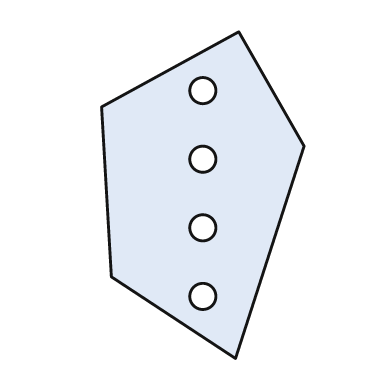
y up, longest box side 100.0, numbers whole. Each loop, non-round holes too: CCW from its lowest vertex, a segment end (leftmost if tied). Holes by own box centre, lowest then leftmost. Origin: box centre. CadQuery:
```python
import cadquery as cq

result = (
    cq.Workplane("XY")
    .moveTo(10.0, -50.0)
    .lineTo(31.0, 15.0)
    .lineTo(11.0, 50.0)
    .lineTo(-31.0, 27.0)
    .lineTo(-28.0, -25.0)
    .close()
    .moveTo(0.0, -31.0)
    .circle(4.0)
    .moveTo(0.0, -10.0)
    .circle(4.0)
    .moveTo(0.0, 11.0)
    .circle(4.0)
    .moveTo(0.0, 32.0)
    .circle(4.0)
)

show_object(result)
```